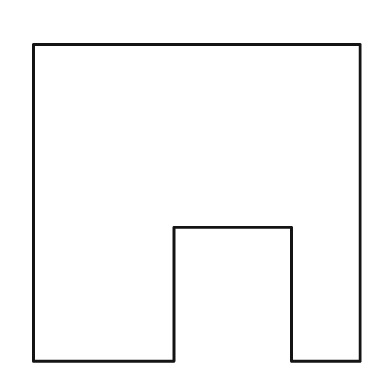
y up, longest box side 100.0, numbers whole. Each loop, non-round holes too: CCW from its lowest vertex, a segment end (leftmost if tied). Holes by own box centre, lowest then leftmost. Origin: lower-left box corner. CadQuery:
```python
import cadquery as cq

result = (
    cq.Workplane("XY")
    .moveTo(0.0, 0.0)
    .lineTo(43.0, 0.0)
    .lineTo(43.0, 41.0)
    .lineTo(79.0, 41.0)
    .lineTo(79.0, 0.0)
    .lineTo(100.0, 0.0)
    .lineTo(100.0, 97.0)
    .lineTo(0.0, 97.0)
    .close()
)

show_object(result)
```